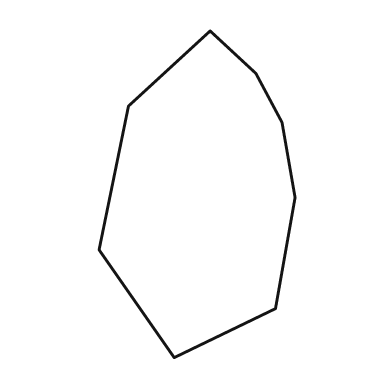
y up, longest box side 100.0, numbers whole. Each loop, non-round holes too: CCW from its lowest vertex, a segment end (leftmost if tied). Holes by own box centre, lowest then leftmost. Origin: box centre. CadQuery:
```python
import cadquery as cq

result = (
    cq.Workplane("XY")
    .moveTo(-7.0, -50.0)
    .lineTo(24.0, -35.0)
    .lineTo(30.0, -1.0)
    .lineTo(26.0, 22.0)
    .lineTo(18.0, 37.0)
    .lineTo(4.0, 50.0)
    .lineTo(-21.0, 27.0)
    .lineTo(-30.0, -17.0)
    .close()
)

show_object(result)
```